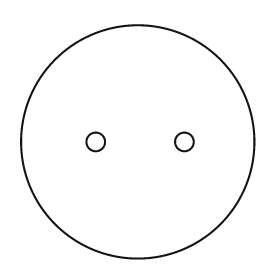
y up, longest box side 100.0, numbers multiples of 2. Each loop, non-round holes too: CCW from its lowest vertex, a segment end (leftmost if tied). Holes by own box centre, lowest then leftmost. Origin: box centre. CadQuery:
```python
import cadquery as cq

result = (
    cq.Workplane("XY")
    .moveTo(0.0, 0.0)
    .circle(50.0)
    .moveTo(-18.0, 0.0)
    .circle(4.0)
    .moveTo(20.0, 0.0)
    .circle(4.0)
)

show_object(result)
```